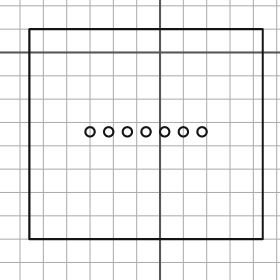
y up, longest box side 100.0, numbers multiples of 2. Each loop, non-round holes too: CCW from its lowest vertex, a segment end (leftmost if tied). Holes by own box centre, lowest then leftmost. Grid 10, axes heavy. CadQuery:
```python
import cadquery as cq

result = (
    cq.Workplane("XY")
    .moveTo(-56.0, -80.0)
    .lineTo(44.0, -80.0)
    .lineTo(44.0, 10.0)
    .lineTo(-56.0, 10.0)
    .close()
    .moveTo(-30.0, -34.0)
    .circle(2.0)
    .moveTo(-22.0, -34.0)
    .circle(2.0)
    .moveTo(-14.0, -34.0)
    .circle(2.0)
    .moveTo(-6.0, -34.0)
    .circle(2.0)
    .moveTo(2.0, -34.0)
    .circle(2.0)
    .moveTo(10.0, -34.0)
    .circle(2.0)
    .moveTo(18.0, -34.0)
    .circle(2.0)
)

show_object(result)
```